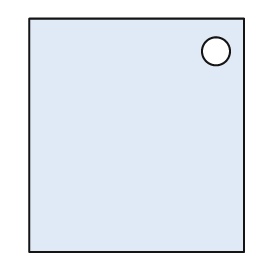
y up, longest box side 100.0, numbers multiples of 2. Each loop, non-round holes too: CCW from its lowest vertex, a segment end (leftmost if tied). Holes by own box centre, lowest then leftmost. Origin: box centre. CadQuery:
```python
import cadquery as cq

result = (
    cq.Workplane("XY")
    .moveTo(-46.0, -50.0)
    .lineTo(46.0, -50.0)
    .lineTo(46.0, 50.0)
    .lineTo(-46.0, 50.0)
    .close()
    .moveTo(34.0, 36.0)
    .circle(6.0)
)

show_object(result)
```